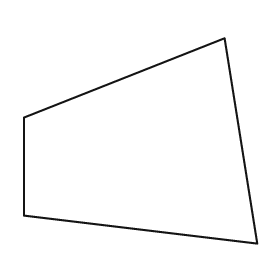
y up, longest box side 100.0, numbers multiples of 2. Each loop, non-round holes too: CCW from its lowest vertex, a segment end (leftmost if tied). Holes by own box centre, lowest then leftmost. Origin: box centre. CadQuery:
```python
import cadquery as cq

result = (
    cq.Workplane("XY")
    .moveTo(50.0, -44.0)
    .lineTo(36.0, 44.0)
    .lineTo(-50.0, 10.0)
    .lineTo(-50.0, -32.0)
    .close()
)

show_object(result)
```